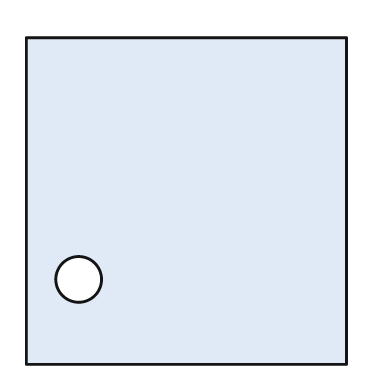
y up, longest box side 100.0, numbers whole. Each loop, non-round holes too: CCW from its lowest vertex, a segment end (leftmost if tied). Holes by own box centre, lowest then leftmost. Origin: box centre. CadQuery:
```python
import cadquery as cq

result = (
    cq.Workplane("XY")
    .moveTo(-49.0, -50.0)
    .lineTo(49.0, -50.0)
    .lineTo(49.0, 50.0)
    .lineTo(-49.0, 50.0)
    .close()
    .moveTo(-33.0, -24.0)
    .circle(7.0)
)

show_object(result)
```